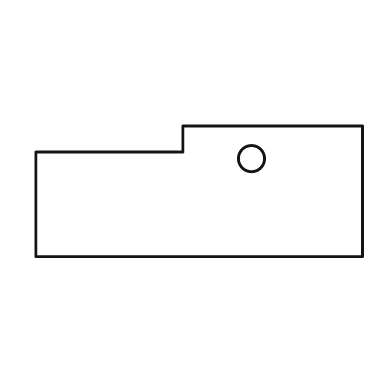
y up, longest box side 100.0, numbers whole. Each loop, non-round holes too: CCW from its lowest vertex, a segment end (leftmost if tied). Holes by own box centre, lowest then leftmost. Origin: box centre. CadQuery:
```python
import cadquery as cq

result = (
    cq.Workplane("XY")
    .moveTo(-50.0, -20.0)
    .lineTo(50.0, -20.0)
    .lineTo(50.0, 20.0)
    .lineTo(-5.0, 20.0)
    .lineTo(-5.0, 12.0)
    .lineTo(-50.0, 12.0)
    .close()
    .moveTo(16.0, 10.0)
    .circle(4.0)
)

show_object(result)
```